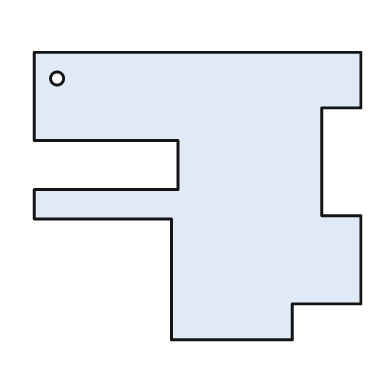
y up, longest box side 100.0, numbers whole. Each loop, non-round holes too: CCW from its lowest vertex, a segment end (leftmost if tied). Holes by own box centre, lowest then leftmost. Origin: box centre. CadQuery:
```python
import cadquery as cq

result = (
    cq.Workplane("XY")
    .moveTo(-8.0, -44.0)
    .lineTo(29.0, -44.0)
    .lineTo(29.0, -33.0)
    .lineTo(50.0, -33.0)
    .lineTo(50.0, -6.0)
    .lineTo(38.0, -6.0)
    .lineTo(38.0, 27.0)
    .lineTo(50.0, 27.0)
    .lineTo(50.0, 44.0)
    .lineTo(-50.0, 44.0)
    .lineTo(-50.0, 17.0)
    .lineTo(-6.0, 17.0)
    .lineTo(-6.0, 2.0)
    .lineTo(-50.0, 2.0)
    .lineTo(-50.0, -7.0)
    .lineTo(-8.0, -7.0)
    .close()
    .moveTo(-43.0, 36.0)
    .circle(2.0)
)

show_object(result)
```